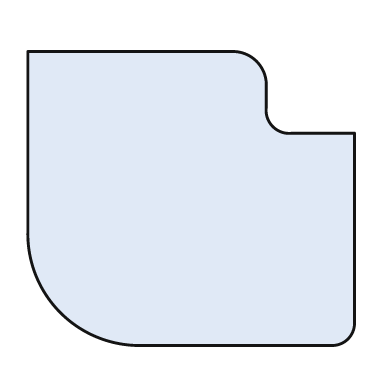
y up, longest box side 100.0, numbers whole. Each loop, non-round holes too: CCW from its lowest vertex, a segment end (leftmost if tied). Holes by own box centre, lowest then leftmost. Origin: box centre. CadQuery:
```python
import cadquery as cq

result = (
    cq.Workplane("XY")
    .moveTo(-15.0, -45.0)
    .lineTo(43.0, -45.0)
    .threePointArc((48.0, -43.0), (50.0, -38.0))
    .lineTo(50.0, 20.0)
    .lineTo(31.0, 20.0)
    .threePointArc((25.0, 22.0), (23.0, 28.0))
    .lineTo(23.0, 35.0)
    .threePointArc((20.0, 42.0), (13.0, 45.0))
    .lineTo(-50.0, 45.0)
    .lineTo(-50.0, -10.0)
    .threePointArc((-40.0, -35.0), (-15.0, -45.0))
    .close()
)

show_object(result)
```